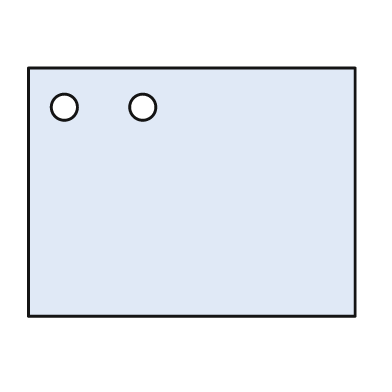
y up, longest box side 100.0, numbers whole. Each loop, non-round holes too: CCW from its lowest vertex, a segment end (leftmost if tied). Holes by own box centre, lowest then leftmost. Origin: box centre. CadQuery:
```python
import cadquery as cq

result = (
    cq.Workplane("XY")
    .moveTo(-50.0, -38.0)
    .lineTo(50.0, -38.0)
    .lineTo(50.0, 38.0)
    .lineTo(-50.0, 38.0)
    .close()
    .moveTo(-39.0, 26.0)
    .circle(4.0)
    .moveTo(-15.0, 26.0)
    .circle(4.0)
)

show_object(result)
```